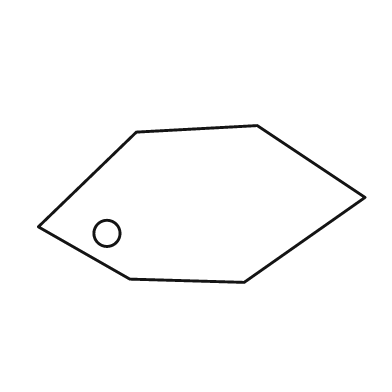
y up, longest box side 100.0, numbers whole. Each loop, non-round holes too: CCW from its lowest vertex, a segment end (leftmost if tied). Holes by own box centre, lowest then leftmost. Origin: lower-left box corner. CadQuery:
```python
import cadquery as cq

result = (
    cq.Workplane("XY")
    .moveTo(63.0, 0.0)
    .lineTo(100.0, 26.0)
    .lineTo(67.0, 48.0)
    .lineTo(30.0, 46.0)
    .lineTo(0.0, 17.0)
    .lineTo(28.0, 1.0)
    .close()
    .moveTo(21.0, 15.0)
    .circle(4.0)
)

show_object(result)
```